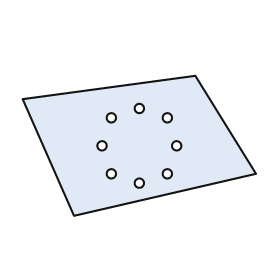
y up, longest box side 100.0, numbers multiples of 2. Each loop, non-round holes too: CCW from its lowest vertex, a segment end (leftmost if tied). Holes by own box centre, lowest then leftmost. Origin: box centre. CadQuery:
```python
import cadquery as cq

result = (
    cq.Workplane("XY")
    .moveTo(-28.0, -30.0)
    .lineTo(50.0, -12.0)
    .lineTo(24.0, 30.0)
    .lineTo(-50.0, 20.0)
    .close()
    .moveTo(0.0, -16.0)
    .circle(2.0)
    .moveTo(-12.0, -12.0)
    .circle(2.0)
    .moveTo(12.0, -12.0)
    .circle(2.0)
    .moveTo(-16.0, 0.0)
    .circle(2.0)
    .moveTo(16.0, 0.0)
    .circle(2.0)
    .moveTo(-12.0, 12.0)
    .circle(2.0)
    .moveTo(12.0, 12.0)
    .circle(2.0)
    .moveTo(0.0, 16.0)
    .circle(2.0)
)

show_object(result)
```